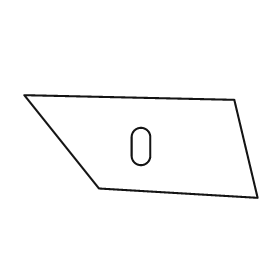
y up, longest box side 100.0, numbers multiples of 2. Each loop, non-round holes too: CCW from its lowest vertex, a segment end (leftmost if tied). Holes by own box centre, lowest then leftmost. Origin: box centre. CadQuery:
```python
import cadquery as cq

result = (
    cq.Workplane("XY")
    .moveTo(50.0, -22.0)
    .lineTo(40.0, 20.0)
    .lineTo(-50.0, 22.0)
    .lineTo(-18.0, -18.0)
    .close()
    .moveTo(-4.0, -4.0)
    .threePointArc((0.0, -8.0), (4.0, -4.0))
    .lineTo(4.0, 4.0)
    .threePointArc((0.0, 8.0), (-4.0, 4.0))
    .close()
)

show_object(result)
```